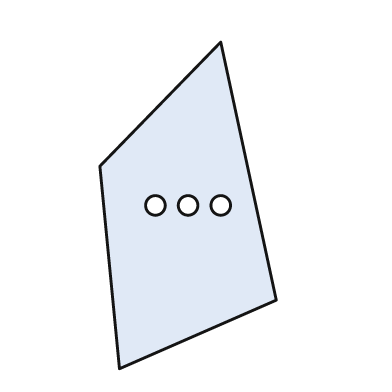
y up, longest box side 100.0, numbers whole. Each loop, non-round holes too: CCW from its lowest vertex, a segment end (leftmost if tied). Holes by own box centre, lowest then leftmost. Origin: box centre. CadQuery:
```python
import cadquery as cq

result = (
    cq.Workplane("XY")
    .moveTo(-21.0, -50.0)
    .lineTo(27.0, -29.0)
    .lineTo(10.0, 50.0)
    .lineTo(-27.0, 12.0)
    .close()
    .moveTo(-10.0, 0.0)
    .circle(3.0)
    .moveTo(0.0, 0.0)
    .circle(3.0)
    .moveTo(10.0, 0.0)
    .circle(3.0)
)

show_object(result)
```